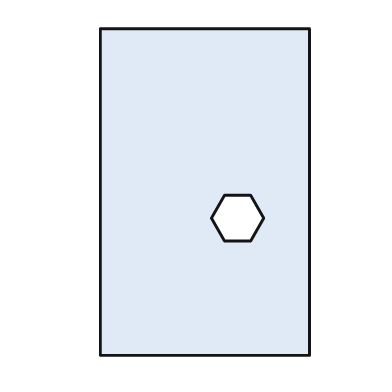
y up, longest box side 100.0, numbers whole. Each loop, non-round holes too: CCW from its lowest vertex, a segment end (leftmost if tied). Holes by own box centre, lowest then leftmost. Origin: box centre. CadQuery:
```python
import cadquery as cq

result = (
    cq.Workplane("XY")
    .moveTo(-32.0, -50.0)
    .lineTo(32.0, -50.0)
    .lineTo(32.0, 50.0)
    .lineTo(-32.0, 50.0)
    .close()
    .moveTo(6.0, -15.0)
    .lineTo(14.0, -15.0)
    .lineTo(18.0, -8.0)
    .lineTo(14.0, -1.0)
    .lineTo(6.0, -1.0)
    .lineTo(2.0, -8.0)
    .close()
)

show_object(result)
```